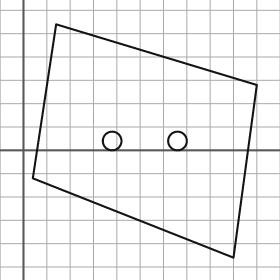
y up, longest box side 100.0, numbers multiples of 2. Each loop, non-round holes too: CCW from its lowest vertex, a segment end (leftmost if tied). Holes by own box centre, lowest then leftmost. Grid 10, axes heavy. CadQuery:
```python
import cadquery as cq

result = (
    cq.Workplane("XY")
    .moveTo(90.0, -46.0)
    .lineTo(100.0, 28.0)
    .lineTo(14.0, 54.0)
    .lineTo(4.0, -12.0)
    .close()
    .moveTo(38.0, 4.0)
    .circle(4.0)
    .moveTo(66.0, 4.0)
    .circle(4.0)
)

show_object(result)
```